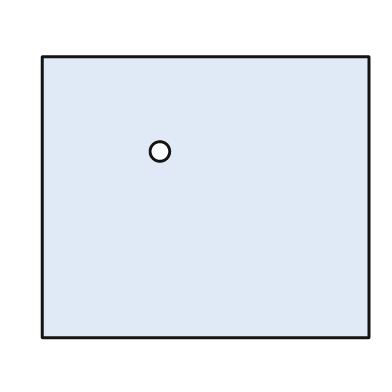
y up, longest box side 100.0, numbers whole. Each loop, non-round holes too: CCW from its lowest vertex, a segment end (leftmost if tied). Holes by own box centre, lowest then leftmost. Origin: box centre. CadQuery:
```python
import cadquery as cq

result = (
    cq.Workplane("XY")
    .moveTo(-50.0, -43.0)
    .lineTo(50.0, -43.0)
    .lineTo(50.0, 43.0)
    .lineTo(-50.0, 43.0)
    .close()
    .moveTo(-14.0, 14.0)
    .circle(3.0)
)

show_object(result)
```